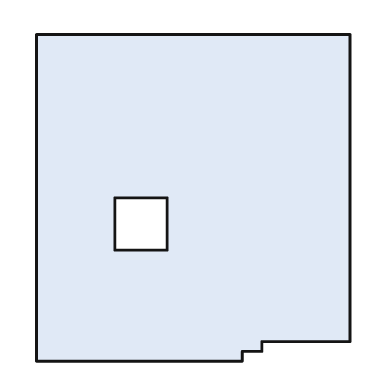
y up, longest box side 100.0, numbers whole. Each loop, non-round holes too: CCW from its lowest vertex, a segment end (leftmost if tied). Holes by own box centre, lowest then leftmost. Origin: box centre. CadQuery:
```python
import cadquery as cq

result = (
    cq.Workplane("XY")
    .moveTo(-48.0, -50.0)
    .lineTo(15.0, -50.0)
    .lineTo(15.0, -47.0)
    .lineTo(21.0, -47.0)
    .lineTo(21.0, -44.0)
    .lineTo(48.0, -44.0)
    .lineTo(48.0, 50.0)
    .lineTo(-48.0, 50.0)
    .close()
    .moveTo(-24.0, -16.0)
    .lineTo(-8.0, -16.0)
    .lineTo(-8.0, 0.0)
    .lineTo(-24.0, 0.0)
    .close()
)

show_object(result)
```